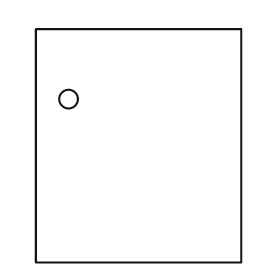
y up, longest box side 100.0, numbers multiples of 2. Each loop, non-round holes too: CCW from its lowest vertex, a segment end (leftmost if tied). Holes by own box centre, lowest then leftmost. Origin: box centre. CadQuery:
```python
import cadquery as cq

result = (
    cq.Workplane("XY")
    .moveTo(-44.0, -50.0)
    .lineTo(44.0, -50.0)
    .lineTo(44.0, 50.0)
    .lineTo(-44.0, 50.0)
    .close()
    .moveTo(-30.0, 20.0)
    .circle(4.0)
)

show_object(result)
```